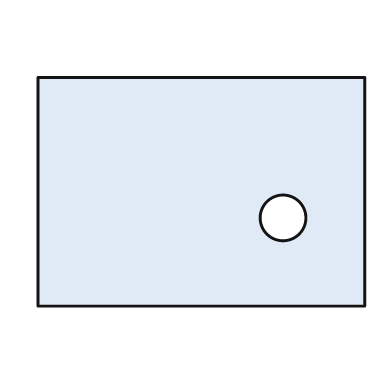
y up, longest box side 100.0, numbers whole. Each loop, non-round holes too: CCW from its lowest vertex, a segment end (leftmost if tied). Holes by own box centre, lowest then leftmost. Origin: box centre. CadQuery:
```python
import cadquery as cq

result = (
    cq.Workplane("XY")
    .moveTo(-50.0, -35.0)
    .lineTo(50.0, -35.0)
    .lineTo(50.0, 35.0)
    .lineTo(-50.0, 35.0)
    .close()
    .moveTo(25.0, -8.0)
    .circle(7.0)
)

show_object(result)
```